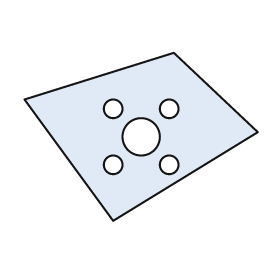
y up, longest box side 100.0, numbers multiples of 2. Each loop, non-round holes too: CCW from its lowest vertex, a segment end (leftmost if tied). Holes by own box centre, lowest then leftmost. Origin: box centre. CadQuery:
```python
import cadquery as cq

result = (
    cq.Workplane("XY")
    .moveTo(-12.0, -36.0)
    .lineTo(50.0, 2.0)
    .lineTo(14.0, 36.0)
    .lineTo(-50.0, 16.0)
    .close()
    .moveTo(-12.0, -12.0)
    .circle(4.0)
    .moveTo(12.0, -12.0)
    .circle(4.0)
    .moveTo(0.0, 0.0)
    .circle(8.0)
    .moveTo(-12.0, 12.0)
    .circle(4.0)
    .moveTo(12.0, 12.0)
    .circle(4.0)
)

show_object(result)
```